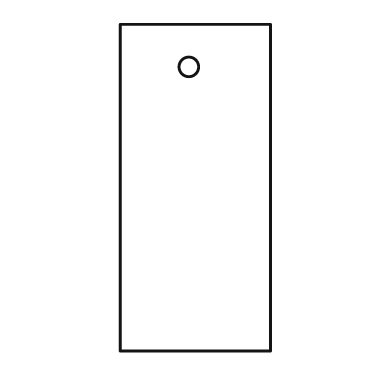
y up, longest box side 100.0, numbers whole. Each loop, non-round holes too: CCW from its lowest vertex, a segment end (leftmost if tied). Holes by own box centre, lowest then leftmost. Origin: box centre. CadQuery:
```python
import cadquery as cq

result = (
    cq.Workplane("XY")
    .moveTo(-23.0, -50.0)
    .lineTo(23.0, -50.0)
    .lineTo(23.0, 50.0)
    .lineTo(-23.0, 50.0)
    .close()
    .moveTo(-2.0, 37.0)
    .circle(3.0)
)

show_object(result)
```